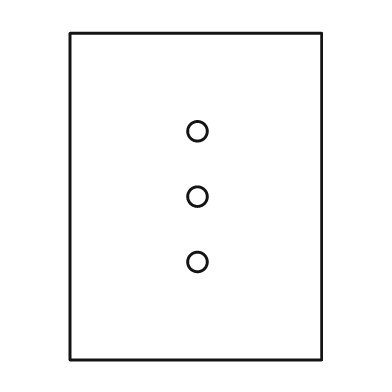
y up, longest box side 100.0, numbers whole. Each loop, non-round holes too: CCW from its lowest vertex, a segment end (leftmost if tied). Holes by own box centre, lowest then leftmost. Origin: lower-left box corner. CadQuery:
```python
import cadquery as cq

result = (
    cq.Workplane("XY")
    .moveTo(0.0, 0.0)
    .lineTo(77.0, 0.0)
    .lineTo(77.0, 100.0)
    .lineTo(0.0, 100.0)
    .close()
    .moveTo(39.0, 30.0)
    .circle(3.0)
    .moveTo(39.0, 50.0)
    .circle(3.0)
    .moveTo(39.0, 70.0)
    .circle(3.0)
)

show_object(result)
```